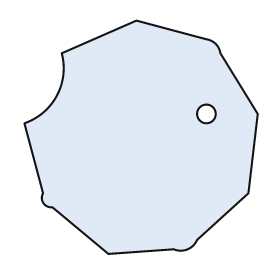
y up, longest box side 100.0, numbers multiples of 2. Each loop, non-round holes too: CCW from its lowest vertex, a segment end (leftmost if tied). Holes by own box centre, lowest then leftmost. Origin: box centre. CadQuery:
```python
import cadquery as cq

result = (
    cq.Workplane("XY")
    .moveTo(-14.0, -50.0)
    .lineTo(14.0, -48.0)
    .threePointArc((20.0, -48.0), (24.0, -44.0))
    .lineTo(46.0, -24.0)
    .lineTo(50.0, 10.0)
    .lineTo(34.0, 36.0)
    .threePointArc((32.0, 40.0), (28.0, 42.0))
    .lineTo(-2.0, 50.0)
    .lineTo(-34.0, 36.0)
    .threePointArc((-36.0, 18.0), (-50.0, 6.0))
    .lineTo(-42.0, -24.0)
    .threePointArc((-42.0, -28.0), (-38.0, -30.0))
    .close()
    .moveTo(28.0, 10.0)
    .circle(4.0)
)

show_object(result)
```